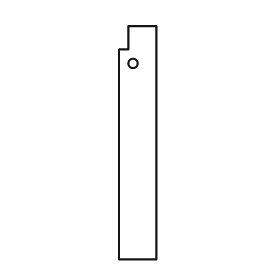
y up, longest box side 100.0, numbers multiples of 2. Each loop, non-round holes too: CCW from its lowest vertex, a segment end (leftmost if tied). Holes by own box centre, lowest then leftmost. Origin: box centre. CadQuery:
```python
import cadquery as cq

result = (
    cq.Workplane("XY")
    .moveTo(-8.0, -50.0)
    .lineTo(8.0, -50.0)
    .lineTo(8.0, 50.0)
    .lineTo(-4.0, 50.0)
    .lineTo(-4.0, 40.0)
    .lineTo(-8.0, 40.0)
    .close()
    .moveTo(-2.0, 34.0)
    .circle(2.0)
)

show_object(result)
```